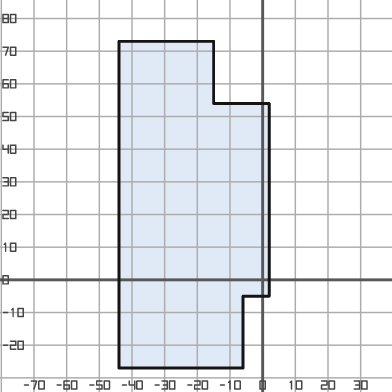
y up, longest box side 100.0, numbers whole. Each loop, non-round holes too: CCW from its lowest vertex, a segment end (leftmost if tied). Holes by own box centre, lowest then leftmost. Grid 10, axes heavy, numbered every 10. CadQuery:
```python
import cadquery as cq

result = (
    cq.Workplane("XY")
    .moveTo(-44.0, -27.0)
    .lineTo(-6.0, -27.0)
    .lineTo(-6.0, -5.0)
    .lineTo(2.0, -5.0)
    .lineTo(2.0, 54.0)
    .lineTo(-15.0, 54.0)
    .lineTo(-15.0, 73.0)
    .lineTo(-44.0, 73.0)
    .close()
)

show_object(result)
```